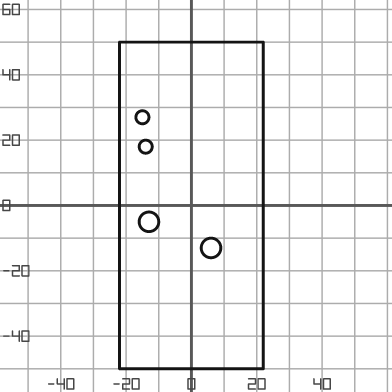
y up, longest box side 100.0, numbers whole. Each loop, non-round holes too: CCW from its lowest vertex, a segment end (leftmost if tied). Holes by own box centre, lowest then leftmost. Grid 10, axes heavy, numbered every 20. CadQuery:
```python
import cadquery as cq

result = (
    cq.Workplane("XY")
    .moveTo(-22.0, -50.0)
    .lineTo(22.0, -50.0)
    .lineTo(22.0, 50.0)
    .lineTo(-22.0, 50.0)
    .close()
    .moveTo(6.0, -13.0)
    .circle(3.0)
    .moveTo(-13.0, -5.0)
    .circle(3.0)
    .moveTo(-14.0, 18.0)
    .circle(2.0)
    .moveTo(-15.0, 27.0)
    .circle(2.0)
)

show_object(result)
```